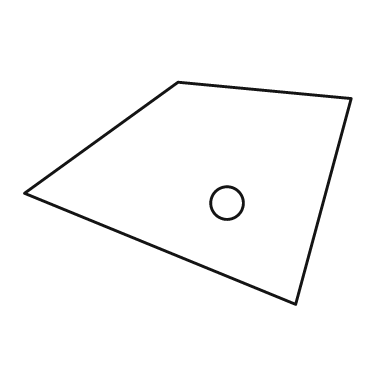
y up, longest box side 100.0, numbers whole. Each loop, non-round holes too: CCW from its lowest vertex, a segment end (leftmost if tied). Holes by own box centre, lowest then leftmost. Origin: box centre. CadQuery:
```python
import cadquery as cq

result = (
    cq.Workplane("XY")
    .moveTo(33.0, -34.0)
    .lineTo(50.0, 29.0)
    .lineTo(-3.0, 34.0)
    .lineTo(-50.0, 0.0)
    .close()
    .moveTo(12.0, -3.0)
    .circle(5.0)
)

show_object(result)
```